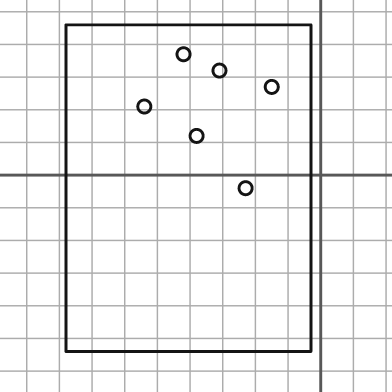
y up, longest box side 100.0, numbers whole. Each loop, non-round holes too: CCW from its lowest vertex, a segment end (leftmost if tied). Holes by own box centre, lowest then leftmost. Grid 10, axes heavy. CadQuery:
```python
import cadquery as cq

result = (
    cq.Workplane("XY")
    .moveTo(-78.0, -54.0)
    .lineTo(-3.0, -54.0)
    .lineTo(-3.0, 46.0)
    .lineTo(-78.0, 46.0)
    .close()
    .moveTo(-23.0, -4.0)
    .circle(2.0)
    .moveTo(-38.0, 12.0)
    .circle(2.0)
    .moveTo(-54.0, 21.0)
    .circle(2.0)
    .moveTo(-15.0, 27.0)
    .circle(2.0)
    .moveTo(-31.0, 32.0)
    .circle(2.0)
    .moveTo(-42.0, 37.0)
    .circle(2.0)
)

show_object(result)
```